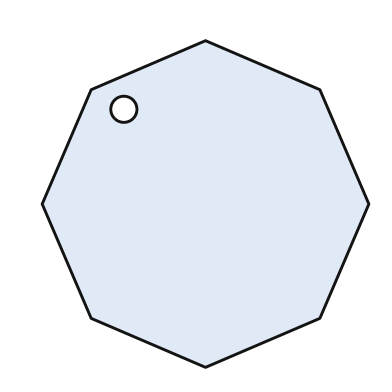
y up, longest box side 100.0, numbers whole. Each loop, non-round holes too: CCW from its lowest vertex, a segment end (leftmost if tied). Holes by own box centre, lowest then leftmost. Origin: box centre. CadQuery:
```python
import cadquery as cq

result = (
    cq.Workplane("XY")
    .moveTo(0.0, -50.0)
    .lineTo(35.0, -35.0)
    .lineTo(50.0, 0.0)
    .lineTo(35.0, 35.0)
    .lineTo(0.0, 50.0)
    .lineTo(-35.0, 35.0)
    .lineTo(-50.0, 0.0)
    .lineTo(-35.0, -35.0)
    .close()
    .moveTo(-25.0, 29.0)
    .circle(4.0)
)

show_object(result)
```